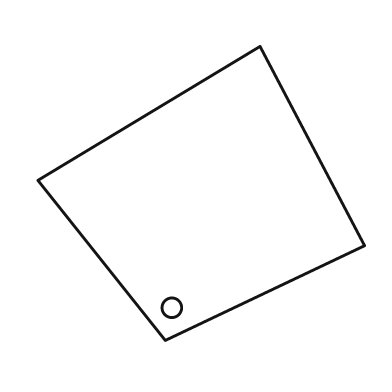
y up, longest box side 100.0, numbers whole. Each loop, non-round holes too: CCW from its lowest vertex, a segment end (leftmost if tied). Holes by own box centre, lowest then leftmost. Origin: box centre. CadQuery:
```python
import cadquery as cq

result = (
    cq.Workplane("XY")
    .moveTo(-11.0, -45.0)
    .lineTo(50.0, -16.0)
    .lineTo(18.0, 45.0)
    .lineTo(-50.0, 4.0)
    .close()
    .moveTo(-9.0, -35.0)
    .circle(3.0)
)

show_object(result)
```